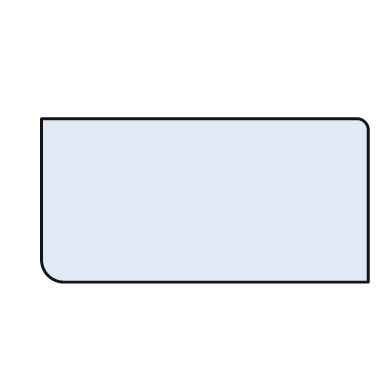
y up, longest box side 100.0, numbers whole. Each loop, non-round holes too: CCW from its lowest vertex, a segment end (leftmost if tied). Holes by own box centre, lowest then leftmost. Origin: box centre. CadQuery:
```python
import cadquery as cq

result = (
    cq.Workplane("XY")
    .moveTo(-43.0, -25.0)
    .lineTo(50.0, -25.0)
    .lineTo(50.0, 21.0)
    .threePointArc((49.0, 24.0), (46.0, 25.0))
    .lineTo(-50.0, 25.0)
    .lineTo(-50.0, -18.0)
    .threePointArc((-48.0, -23.0), (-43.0, -25.0))
    .close()
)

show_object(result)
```